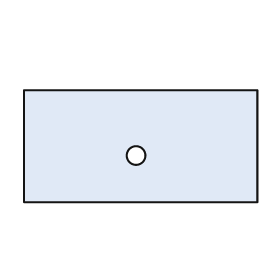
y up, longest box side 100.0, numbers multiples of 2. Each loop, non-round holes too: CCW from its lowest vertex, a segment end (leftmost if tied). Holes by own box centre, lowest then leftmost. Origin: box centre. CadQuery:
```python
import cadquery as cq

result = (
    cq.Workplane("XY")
    .moveTo(-50.0, -24.0)
    .lineTo(50.0, -24.0)
    .lineTo(50.0, 24.0)
    .lineTo(-50.0, 24.0)
    .close()
    .moveTo(-2.0, -4.0)
    .circle(4.0)
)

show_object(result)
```